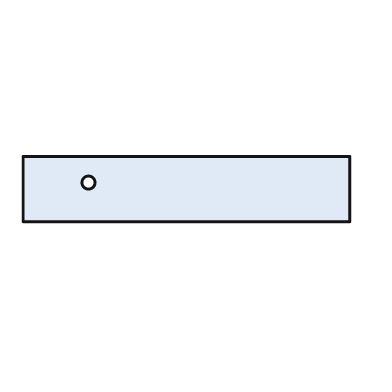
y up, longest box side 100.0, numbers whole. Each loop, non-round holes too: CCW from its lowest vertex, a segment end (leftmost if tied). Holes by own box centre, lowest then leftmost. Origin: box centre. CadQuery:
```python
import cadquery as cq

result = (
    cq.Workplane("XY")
    .moveTo(-50.0, -10.0)
    .lineTo(50.0, -10.0)
    .lineTo(50.0, 10.0)
    .lineTo(-50.0, 10.0)
    .close()
    .moveTo(-30.0, 2.0)
    .circle(2.0)
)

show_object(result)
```